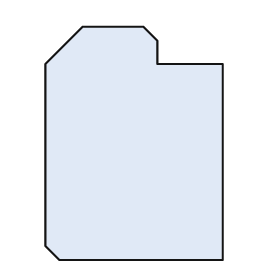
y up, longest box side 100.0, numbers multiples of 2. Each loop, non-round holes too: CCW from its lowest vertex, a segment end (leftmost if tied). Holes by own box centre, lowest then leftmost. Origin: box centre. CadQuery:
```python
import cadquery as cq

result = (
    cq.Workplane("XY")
    .moveTo(-32.0, -50.0)
    .lineTo(38.0, -50.0)
    .lineTo(38.0, 34.0)
    .lineTo(10.0, 34.0)
    .lineTo(10.0, 44.0)
    .lineTo(4.0, 50.0)
    .lineTo(-22.0, 50.0)
    .lineTo(-38.0, 34.0)
    .lineTo(-38.0, -44.0)
    .close()
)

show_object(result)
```